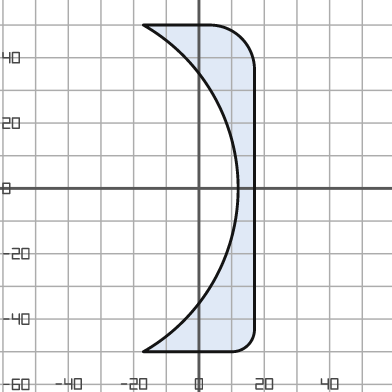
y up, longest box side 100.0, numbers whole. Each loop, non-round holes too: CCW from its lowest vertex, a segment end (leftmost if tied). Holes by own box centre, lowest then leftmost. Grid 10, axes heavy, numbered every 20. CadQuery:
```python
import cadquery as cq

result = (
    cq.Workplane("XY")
    .moveTo(-17.0, -50.0)
    .lineTo(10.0, -50.0)
    .threePointArc((15.0, -48.0), (17.0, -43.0))
    .lineTo(17.0, 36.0)
    .threePointArc((13.0, 46.0), (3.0, 50.0))
    .lineTo(-17.0, 50.0)
    .threePointArc((12.0, 0.0), (-17.0, -50.0))
    .close()
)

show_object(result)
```